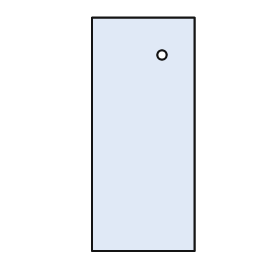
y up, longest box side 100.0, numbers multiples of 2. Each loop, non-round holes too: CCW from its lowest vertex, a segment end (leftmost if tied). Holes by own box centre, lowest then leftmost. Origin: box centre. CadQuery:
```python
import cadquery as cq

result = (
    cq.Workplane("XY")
    .moveTo(-22.0, -50.0)
    .lineTo(22.0, -50.0)
    .lineTo(22.0, 50.0)
    .lineTo(-22.0, 50.0)
    .close()
    .moveTo(8.0, 34.0)
    .circle(2.0)
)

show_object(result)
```